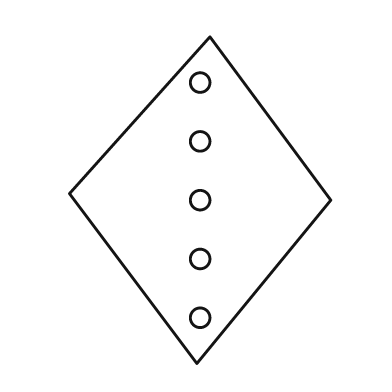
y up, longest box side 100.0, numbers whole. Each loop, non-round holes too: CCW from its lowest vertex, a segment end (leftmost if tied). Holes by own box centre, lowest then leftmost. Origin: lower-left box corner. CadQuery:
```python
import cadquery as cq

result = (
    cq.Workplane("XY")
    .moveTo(39.0, 0.0)
    .lineTo(80.0, 50.0)
    .lineTo(43.0, 100.0)
    .lineTo(0.0, 52.0)
    .close()
    .moveTo(40.0, 14.0)
    .circle(3.0)
    .moveTo(40.0, 32.0)
    .circle(3.0)
    .moveTo(40.0, 50.0)
    .circle(3.0)
    .moveTo(40.0, 68.0)
    .circle(3.0)
    .moveTo(40.0, 86.0)
    .circle(3.0)
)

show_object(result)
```